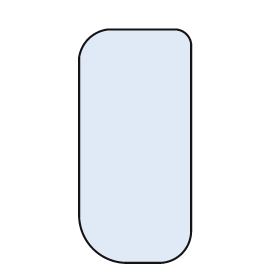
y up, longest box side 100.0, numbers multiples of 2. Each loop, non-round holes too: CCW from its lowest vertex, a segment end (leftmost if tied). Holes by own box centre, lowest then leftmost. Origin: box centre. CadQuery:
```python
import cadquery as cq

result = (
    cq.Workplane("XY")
    .moveTo(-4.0, -50.0)
    .lineTo(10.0, -50.0)
    .threePointArc((20.0, -46.0), (24.0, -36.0))
    .lineTo(24.0, 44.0)
    .threePointArc((22.0, 48.0), (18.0, 50.0))
    .lineTo(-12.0, 50.0)
    .threePointArc((-20.0, 46.0), (-24.0, 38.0))
    .lineTo(-24.0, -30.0)
    .threePointArc((-18.0, -44.0), (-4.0, -50.0))
    .close()
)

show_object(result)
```